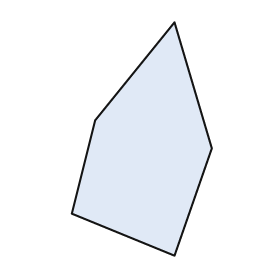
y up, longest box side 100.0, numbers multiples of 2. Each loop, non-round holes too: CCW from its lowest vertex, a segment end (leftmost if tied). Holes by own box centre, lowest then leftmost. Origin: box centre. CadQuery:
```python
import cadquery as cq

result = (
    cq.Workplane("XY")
    .moveTo(14.0, -50.0)
    .lineTo(30.0, -4.0)
    .lineTo(14.0, 50.0)
    .lineTo(-20.0, 8.0)
    .lineTo(-30.0, -32.0)
    .close()
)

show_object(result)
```